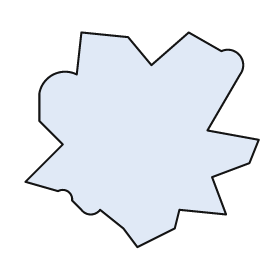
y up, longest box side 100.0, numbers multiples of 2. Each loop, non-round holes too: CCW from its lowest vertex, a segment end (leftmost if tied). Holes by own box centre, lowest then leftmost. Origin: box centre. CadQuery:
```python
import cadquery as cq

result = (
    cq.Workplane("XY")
    .moveTo(-2.0, -46.0)
    .lineTo(14.0, -38.0)
    .lineTo(16.0, -30.0)
    .lineTo(36.0, -32.0)
    .lineTo(30.0, -16.0)
    .lineTo(46.0, -10.0)
    .lineTo(50.0, 0.0)
    .lineTo(28.0, 4.0)
    .lineTo(42.0, 28.0)
    .threePointArc((42.0, 36.0), (34.0, 38.0))
    .lineTo(20.0, 46.0)
    .lineTo(4.0, 32.0)
    .lineTo(-6.0, 44.0)
    .lineTo(-26.0, 46.0)
    .lineTo(-28.0, 28.0)
    .threePointArc((-38.0, 28.0), (-44.0, 20.0))
    .lineTo(-44.0, 8.0)
    .lineTo(-34.0, -2.0)
    .lineTo(-50.0, -18.0)
    .lineTo(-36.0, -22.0)
    .threePointArc((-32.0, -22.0), (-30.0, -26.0))
    .lineTo(-26.0, -30.0)
    .threePointArc((-22.0, -32.0), (-18.0, -30.0))
    .lineTo(-8.0, -38.0)
    .close()
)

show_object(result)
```